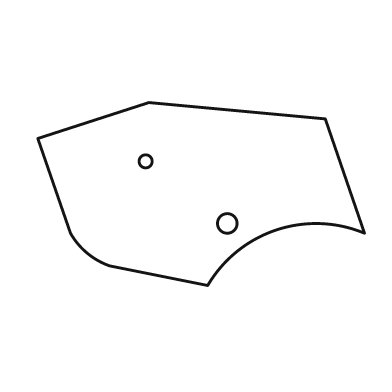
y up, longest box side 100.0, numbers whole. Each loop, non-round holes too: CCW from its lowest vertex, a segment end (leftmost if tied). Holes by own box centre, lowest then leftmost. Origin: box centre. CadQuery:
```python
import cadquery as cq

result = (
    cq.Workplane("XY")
    .moveTo(2.0, -28.0)
    .threePointArc((23.0, -11.0), (50.0, -12.0))
    .lineTo(38.0, 23.0)
    .lineTo(-16.0, 28.0)
    .lineTo(-50.0, 17.0)
    .lineTo(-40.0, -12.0)
    .threePointArc((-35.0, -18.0), (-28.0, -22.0))
    .close()
    .moveTo(8.0, -9.0)
    .circle(3.0)
    .moveTo(-17.0, 10.0)
    .circle(2.0)
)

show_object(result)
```